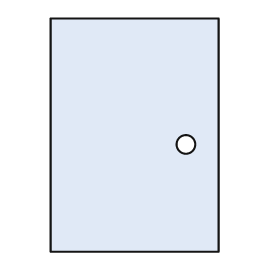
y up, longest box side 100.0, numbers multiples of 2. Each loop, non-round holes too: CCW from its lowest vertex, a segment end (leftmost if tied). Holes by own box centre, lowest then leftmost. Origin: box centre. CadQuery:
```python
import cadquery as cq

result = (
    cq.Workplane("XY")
    .moveTo(-36.0, -50.0)
    .lineTo(36.0, -50.0)
    .lineTo(36.0, 50.0)
    .lineTo(-36.0, 50.0)
    .close()
    .moveTo(22.0, -4.0)
    .circle(4.0)
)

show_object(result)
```